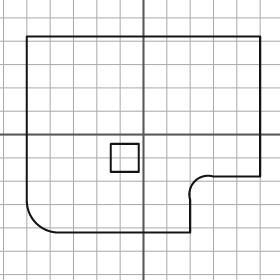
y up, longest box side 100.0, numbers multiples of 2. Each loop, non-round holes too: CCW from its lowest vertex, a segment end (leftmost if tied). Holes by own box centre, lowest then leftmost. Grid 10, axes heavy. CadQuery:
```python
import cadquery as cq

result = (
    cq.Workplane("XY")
    .moveTo(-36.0, -42.0)
    .lineTo(20.0, -42.0)
    .lineTo(20.0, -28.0)
    .threePointArc((22.0, -20.0), (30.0, -18.0))
    .lineTo(50.0, -18.0)
    .lineTo(50.0, 42.0)
    .lineTo(-50.0, 42.0)
    .lineTo(-50.0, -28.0)
    .threePointArc((-46.0, -38.0), (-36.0, -42.0))
    .close()
    .moveTo(-14.0, -16.0)
    .lineTo(-2.0, -16.0)
    .lineTo(-2.0, -4.0)
    .lineTo(-14.0, -4.0)
    .close()
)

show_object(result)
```